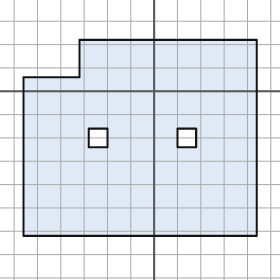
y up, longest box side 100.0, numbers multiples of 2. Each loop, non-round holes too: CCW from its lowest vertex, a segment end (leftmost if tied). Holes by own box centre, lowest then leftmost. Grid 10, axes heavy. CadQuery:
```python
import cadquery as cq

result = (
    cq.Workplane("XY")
    .moveTo(-56.0, -62.0)
    .lineTo(44.0, -62.0)
    .lineTo(44.0, 22.0)
    .lineTo(-32.0, 22.0)
    .lineTo(-32.0, 6.0)
    .lineTo(-56.0, 6.0)
    .close()
    .moveTo(-28.0, -24.0)
    .lineTo(-20.0, -24.0)
    .lineTo(-20.0, -16.0)
    .lineTo(-28.0, -16.0)
    .close()
    .moveTo(10.0, -24.0)
    .lineTo(18.0, -24.0)
    .lineTo(18.0, -16.0)
    .lineTo(10.0, -16.0)
    .close()
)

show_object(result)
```